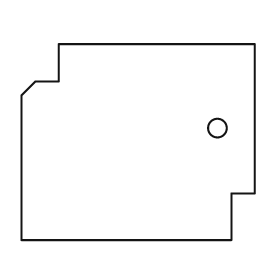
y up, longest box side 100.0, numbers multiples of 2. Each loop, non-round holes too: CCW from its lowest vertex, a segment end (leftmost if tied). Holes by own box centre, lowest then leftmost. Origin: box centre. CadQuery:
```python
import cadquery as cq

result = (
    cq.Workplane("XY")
    .moveTo(-50.0, -42.0)
    .lineTo(40.0, -42.0)
    .lineTo(40.0, -22.0)
    .lineTo(50.0, -22.0)
    .lineTo(50.0, 42.0)
    .lineTo(-34.0, 42.0)
    .lineTo(-34.0, 26.0)
    .lineTo(-44.0, 26.0)
    .lineTo(-50.0, 20.0)
    .close()
    .moveTo(34.0, 6.0)
    .circle(4.0)
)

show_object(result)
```